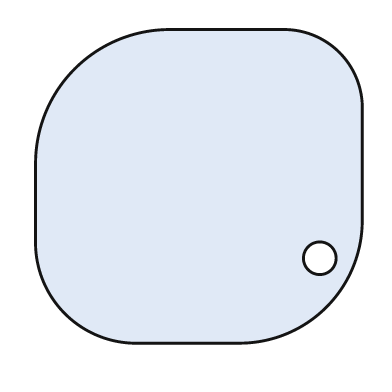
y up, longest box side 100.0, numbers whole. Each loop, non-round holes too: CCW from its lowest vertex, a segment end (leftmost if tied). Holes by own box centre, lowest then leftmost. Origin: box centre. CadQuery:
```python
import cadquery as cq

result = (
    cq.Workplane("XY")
    .moveTo(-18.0, -48.0)
    .lineTo(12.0, -48.0)
    .threePointArc((39.0, -37.0), (50.0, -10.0))
    .lineTo(50.0, 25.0)
    .threePointArc((43.0, 41.0), (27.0, 48.0))
    .lineTo(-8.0, 48.0)
    .threePointArc((-38.0, 36.0), (-50.0, 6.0))
    .lineTo(-50.0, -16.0)
    .threePointArc((-41.0, -39.0), (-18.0, -48.0))
    .close()
    .moveTo(37.0, -22.0)
    .circle(5.0)
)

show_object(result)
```